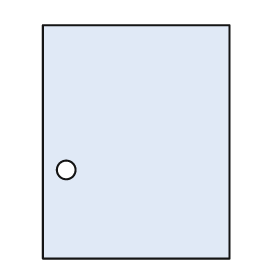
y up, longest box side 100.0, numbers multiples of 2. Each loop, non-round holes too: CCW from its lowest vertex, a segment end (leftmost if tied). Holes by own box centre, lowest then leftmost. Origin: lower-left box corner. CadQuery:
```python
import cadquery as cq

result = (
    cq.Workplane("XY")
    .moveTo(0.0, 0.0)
    .lineTo(80.0, 0.0)
    .lineTo(80.0, 100.0)
    .lineTo(0.0, 100.0)
    .close()
    .moveTo(10.0, 38.0)
    .circle(4.0)
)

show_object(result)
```